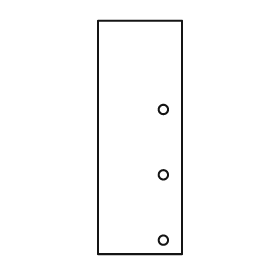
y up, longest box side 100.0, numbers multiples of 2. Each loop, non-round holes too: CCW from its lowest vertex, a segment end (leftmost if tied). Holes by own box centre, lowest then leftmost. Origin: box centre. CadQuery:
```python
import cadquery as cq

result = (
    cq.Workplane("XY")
    .moveTo(-18.0, -50.0)
    .lineTo(18.0, -50.0)
    .lineTo(18.0, 50.0)
    .lineTo(-18.0, 50.0)
    .close()
    .moveTo(10.0, -44.0)
    .circle(2.0)
    .moveTo(10.0, -16.0)
    .circle(2.0)
    .moveTo(10.0, 12.0)
    .circle(2.0)
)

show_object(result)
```